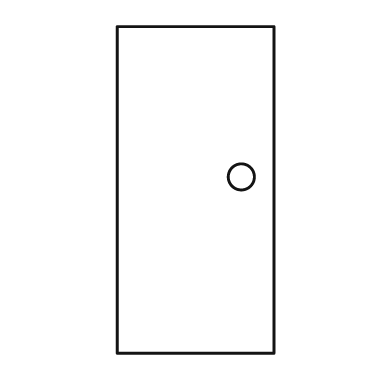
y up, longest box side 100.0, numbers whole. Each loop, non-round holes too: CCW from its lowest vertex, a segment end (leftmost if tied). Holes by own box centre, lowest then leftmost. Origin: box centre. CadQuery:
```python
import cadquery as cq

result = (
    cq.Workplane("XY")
    .moveTo(-24.0, -50.0)
    .lineTo(24.0, -50.0)
    .lineTo(24.0, 50.0)
    .lineTo(-24.0, 50.0)
    .close()
    .moveTo(14.0, 4.0)
    .circle(4.0)
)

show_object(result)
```